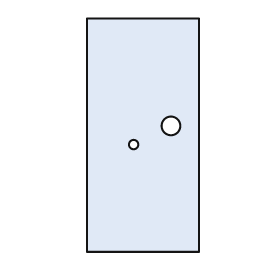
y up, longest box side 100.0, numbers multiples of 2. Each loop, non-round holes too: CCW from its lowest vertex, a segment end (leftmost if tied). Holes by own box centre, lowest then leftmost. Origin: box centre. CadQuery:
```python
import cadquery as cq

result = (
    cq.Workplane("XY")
    .moveTo(-24.0, -50.0)
    .lineTo(24.0, -50.0)
    .lineTo(24.0, 50.0)
    .lineTo(-24.0, 50.0)
    .close()
    .moveTo(-4.0, -4.0)
    .circle(2.0)
    .moveTo(12.0, 4.0)
    .circle(4.0)
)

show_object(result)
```